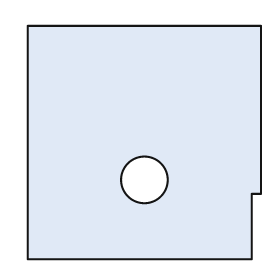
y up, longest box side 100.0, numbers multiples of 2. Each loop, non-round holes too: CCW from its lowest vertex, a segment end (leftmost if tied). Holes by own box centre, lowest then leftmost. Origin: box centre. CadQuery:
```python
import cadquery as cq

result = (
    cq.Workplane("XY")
    .moveTo(-50.0, -50.0)
    .lineTo(46.0, -50.0)
    .lineTo(46.0, -22.0)
    .lineTo(50.0, -22.0)
    .lineTo(50.0, 50.0)
    .lineTo(-50.0, 50.0)
    .close()
    .moveTo(0.0, -16.0)
    .circle(10.0)
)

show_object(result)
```